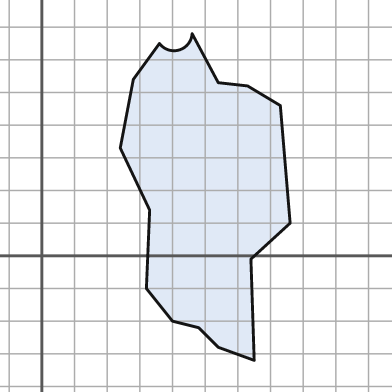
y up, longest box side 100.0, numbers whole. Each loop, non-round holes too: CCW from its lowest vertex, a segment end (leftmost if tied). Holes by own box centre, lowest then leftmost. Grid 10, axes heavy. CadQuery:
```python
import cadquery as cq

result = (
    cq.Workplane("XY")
    .moveTo(65.0, -32.0)
    .lineTo(64.0, -1.0)
    .lineTo(76.0, 10.0)
    .lineTo(73.0, 46.0)
    .lineTo(63.0, 52.0)
    .lineTo(54.0, 53.0)
    .lineTo(46.0, 68.0)
    .threePointArc((42.0, 63.0), (36.0, 65.0))
    .lineTo(28.0, 54.0)
    .lineTo(24.0, 33.0)
    .lineTo(33.0, 14.0)
    .lineTo(32.0, -10.0)
    .lineTo(40.0, -20.0)
    .lineTo(48.0, -22.0)
    .lineTo(54.0, -28.0)
    .close()
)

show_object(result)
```